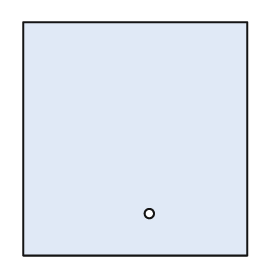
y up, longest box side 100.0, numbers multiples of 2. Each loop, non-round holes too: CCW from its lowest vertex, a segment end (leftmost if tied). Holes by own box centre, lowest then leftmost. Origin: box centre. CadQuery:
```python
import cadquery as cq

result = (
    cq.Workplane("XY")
    .moveTo(-48.0, -50.0)
    .lineTo(48.0, -50.0)
    .lineTo(48.0, 50.0)
    .lineTo(-48.0, 50.0)
    .close()
    .moveTo(6.0, -32.0)
    .circle(2.0)
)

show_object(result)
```